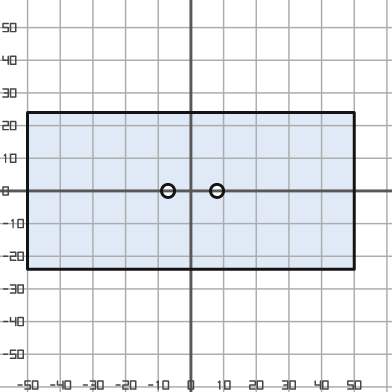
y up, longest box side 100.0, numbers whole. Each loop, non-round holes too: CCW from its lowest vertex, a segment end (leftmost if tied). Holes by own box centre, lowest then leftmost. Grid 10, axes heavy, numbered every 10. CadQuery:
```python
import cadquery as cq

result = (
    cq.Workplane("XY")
    .moveTo(-50.0, -24.0)
    .lineTo(50.0, -24.0)
    .lineTo(50.0, 24.0)
    .lineTo(-50.0, 24.0)
    .close()
    .moveTo(-7.0, 0.0)
    .circle(2.0)
    .moveTo(8.0, 0.0)
    .circle(2.0)
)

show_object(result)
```